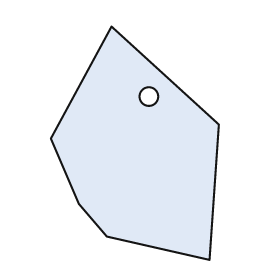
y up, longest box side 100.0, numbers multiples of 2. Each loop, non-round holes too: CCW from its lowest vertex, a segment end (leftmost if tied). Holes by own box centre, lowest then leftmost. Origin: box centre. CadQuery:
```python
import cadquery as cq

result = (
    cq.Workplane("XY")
    .moveTo(32.0, -50.0)
    .lineTo(36.0, 8.0)
    .lineTo(-10.0, 50.0)
    .lineTo(-36.0, 2.0)
    .lineTo(-24.0, -26.0)
    .lineTo(-12.0, -40.0)
    .close()
    .moveTo(6.0, 20.0)
    .circle(4.0)
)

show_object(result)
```